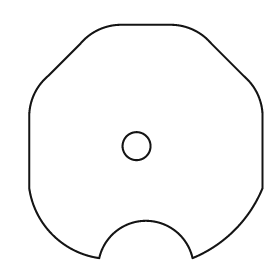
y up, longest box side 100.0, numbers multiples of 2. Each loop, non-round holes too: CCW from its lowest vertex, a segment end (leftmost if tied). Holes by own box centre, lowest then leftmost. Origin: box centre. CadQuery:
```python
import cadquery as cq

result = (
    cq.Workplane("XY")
    .moveTo(-20.0, -50.0)
    .threePointArc((0.0, -34.0), (20.0, -50.0))
    .threePointArc((38.0, -38.0), (50.0, -20.0))
    .lineTo(50.0, 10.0)
    .threePointArc((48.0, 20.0), (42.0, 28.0))
    .lineTo(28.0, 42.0)
    .threePointArc((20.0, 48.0), (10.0, 50.0))
    .lineTo(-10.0, 50.0)
    .threePointArc((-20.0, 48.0), (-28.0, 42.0))
    .lineTo(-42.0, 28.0)
    .threePointArc((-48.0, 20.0), (-50.0, 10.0))
    .lineTo(-50.0, -20.0)
    .threePointArc((-40.0, -40.0), (-20.0, -50.0))
    .close()
    .moveTo(-4.0, -2.0)
    .circle(6.0)
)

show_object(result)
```